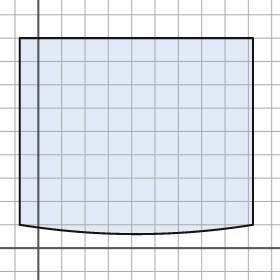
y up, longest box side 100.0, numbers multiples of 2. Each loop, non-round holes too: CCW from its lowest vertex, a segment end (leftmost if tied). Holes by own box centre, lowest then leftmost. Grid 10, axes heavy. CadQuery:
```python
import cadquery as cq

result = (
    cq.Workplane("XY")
    .moveTo(-8.0, 10.0)
    .threePointArc((42.0, 6.0), (92.0, 10.0))
    .lineTo(92.0, 90.0)
    .lineTo(-8.0, 90.0)
    .close()
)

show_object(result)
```